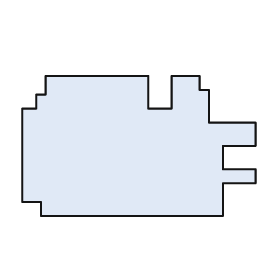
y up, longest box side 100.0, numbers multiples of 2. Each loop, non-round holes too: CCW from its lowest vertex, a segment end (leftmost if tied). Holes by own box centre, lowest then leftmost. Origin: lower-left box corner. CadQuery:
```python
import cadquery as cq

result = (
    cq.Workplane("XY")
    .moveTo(8.0, 0.0)
    .lineTo(86.0, 0.0)
    .lineTo(86.0, 14.0)
    .lineTo(100.0, 14.0)
    .lineTo(100.0, 20.0)
    .lineTo(86.0, 20.0)
    .lineTo(86.0, 30.0)
    .lineTo(100.0, 30.0)
    .lineTo(100.0, 40.0)
    .lineTo(80.0, 40.0)
    .lineTo(80.0, 54.0)
    .lineTo(76.0, 54.0)
    .lineTo(76.0, 60.0)
    .lineTo(64.0, 60.0)
    .lineTo(64.0, 46.0)
    .lineTo(54.0, 46.0)
    .lineTo(54.0, 60.0)
    .lineTo(10.0, 60.0)
    .lineTo(10.0, 52.0)
    .lineTo(6.0, 52.0)
    .lineTo(6.0, 46.0)
    .lineTo(0.0, 46.0)
    .lineTo(0.0, 6.0)
    .lineTo(8.0, 6.0)
    .close()
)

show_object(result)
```